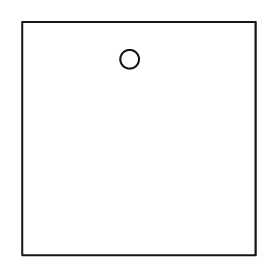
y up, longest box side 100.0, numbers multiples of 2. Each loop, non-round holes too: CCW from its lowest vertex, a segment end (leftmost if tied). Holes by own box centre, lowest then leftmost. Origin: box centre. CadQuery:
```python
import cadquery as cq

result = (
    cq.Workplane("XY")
    .moveTo(-50.0, -50.0)
    .lineTo(50.0, -50.0)
    .lineTo(50.0, 50.0)
    .lineTo(-50.0, 50.0)
    .close()
    .moveTo(-4.0, 34.0)
    .circle(4.0)
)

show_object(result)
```